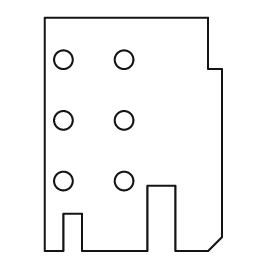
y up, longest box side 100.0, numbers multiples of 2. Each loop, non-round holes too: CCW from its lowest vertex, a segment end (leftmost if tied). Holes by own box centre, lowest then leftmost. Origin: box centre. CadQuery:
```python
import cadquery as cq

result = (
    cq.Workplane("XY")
    .moveTo(-38.0, -50.0)
    .lineTo(-30.0, -50.0)
    .lineTo(-30.0, -34.0)
    .lineTo(-22.0, -34.0)
    .lineTo(-22.0, -50.0)
    .lineTo(6.0, -50.0)
    .lineTo(6.0, -22.0)
    .lineTo(18.0, -22.0)
    .lineTo(18.0, -50.0)
    .lineTo(32.0, -50.0)
    .lineTo(38.0, -44.0)
    .lineTo(38.0, 28.0)
    .lineTo(32.0, 28.0)
    .lineTo(32.0, 50.0)
    .lineTo(-38.0, 50.0)
    .close()
    .moveTo(-30.0, -20.0)
    .circle(4.0)
    .moveTo(-4.0, -20.0)
    .circle(4.0)
    .moveTo(-30.0, 6.0)
    .circle(4.0)
    .moveTo(-4.0, 6.0)
    .circle(4.0)
    .moveTo(-30.0, 32.0)
    .circle(4.0)
    .moveTo(-4.0, 32.0)
    .circle(4.0)
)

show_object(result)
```